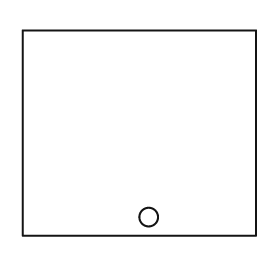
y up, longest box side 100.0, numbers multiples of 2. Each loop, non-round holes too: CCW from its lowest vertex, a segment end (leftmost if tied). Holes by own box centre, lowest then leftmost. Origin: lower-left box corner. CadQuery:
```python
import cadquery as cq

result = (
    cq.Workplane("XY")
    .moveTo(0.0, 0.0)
    .lineTo(100.0, 0.0)
    .lineTo(100.0, 88.0)
    .lineTo(0.0, 88.0)
    .close()
    .moveTo(54.0, 8.0)
    .circle(4.0)
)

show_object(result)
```